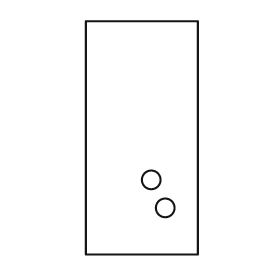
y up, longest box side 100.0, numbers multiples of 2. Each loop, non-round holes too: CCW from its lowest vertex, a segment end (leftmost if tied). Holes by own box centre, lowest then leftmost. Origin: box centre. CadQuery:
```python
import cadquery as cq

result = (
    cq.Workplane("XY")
    .moveTo(-24.0, -50.0)
    .lineTo(24.0, -50.0)
    .lineTo(24.0, 50.0)
    .lineTo(-24.0, 50.0)
    .close()
    .moveTo(10.0, -30.0)
    .circle(4.0)
    .moveTo(4.0, -18.0)
    .circle(4.0)
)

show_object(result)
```